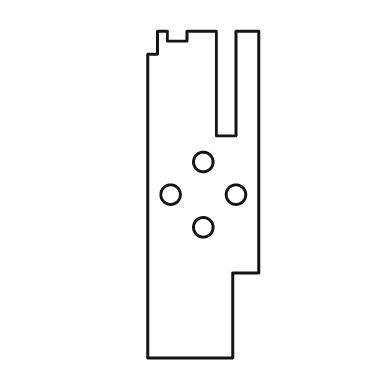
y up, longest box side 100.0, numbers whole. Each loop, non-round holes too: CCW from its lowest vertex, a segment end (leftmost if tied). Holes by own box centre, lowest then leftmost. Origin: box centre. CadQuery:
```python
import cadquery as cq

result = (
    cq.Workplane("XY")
    .moveTo(-17.0, -50.0)
    .lineTo(9.0, -50.0)
    .lineTo(9.0, -24.0)
    .lineTo(17.0, -24.0)
    .lineTo(17.0, 50.0)
    .lineTo(10.0, 50.0)
    .lineTo(10.0, 18.0)
    .lineTo(4.0, 18.0)
    .lineTo(4.0, 50.0)
    .lineTo(-5.0, 50.0)
    .lineTo(-5.0, 47.0)
    .lineTo(-11.0, 47.0)
    .lineTo(-11.0, 50.0)
    .lineTo(-14.0, 50.0)
    .lineTo(-14.0, 43.0)
    .lineTo(-17.0, 43.0)
    .close()
    .moveTo(0.0, -10.0)
    .circle(3.0)
    .moveTo(-10.0, 0.0)
    .circle(3.0)
    .moveTo(10.0, 0.0)
    .circle(3.0)
    .moveTo(0.0, 10.0)
    .circle(3.0)
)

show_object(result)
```